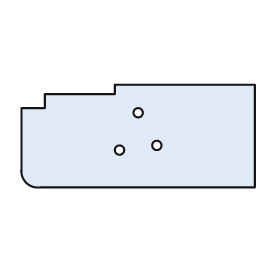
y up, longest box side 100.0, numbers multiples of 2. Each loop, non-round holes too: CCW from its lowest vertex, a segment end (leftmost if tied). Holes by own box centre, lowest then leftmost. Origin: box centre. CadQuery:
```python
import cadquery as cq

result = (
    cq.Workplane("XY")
    .moveTo(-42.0, -22.0)
    .lineTo(50.0, -22.0)
    .lineTo(50.0, 22.0)
    .lineTo(-10.0, 22.0)
    .lineTo(-10.0, 18.0)
    .lineTo(-40.0, 18.0)
    .lineTo(-40.0, 12.0)
    .lineTo(-50.0, 12.0)
    .lineTo(-50.0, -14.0)
    .threePointArc((-48.0, -20.0), (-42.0, -22.0))
    .close()
    .moveTo(-8.0, -6.0)
    .circle(2.0)
    .moveTo(8.0, -4.0)
    .circle(2.0)
    .moveTo(0.0, 10.0)
    .circle(2.0)
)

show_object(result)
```